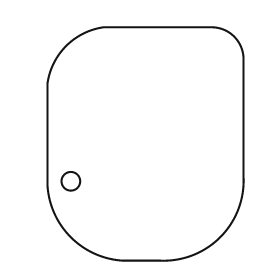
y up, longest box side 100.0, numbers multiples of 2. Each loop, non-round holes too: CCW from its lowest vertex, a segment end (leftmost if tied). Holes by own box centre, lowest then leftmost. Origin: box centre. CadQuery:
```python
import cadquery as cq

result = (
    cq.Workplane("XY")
    .moveTo(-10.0, -50.0)
    .lineTo(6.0, -50.0)
    .threePointArc((32.0, -40.0), (42.0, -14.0))
    .lineTo(42.0, 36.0)
    .threePointArc((38.0, 46.0), (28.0, 50.0))
    .lineTo(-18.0, 50.0)
    .threePointArc((-34.0, 42.0), (-42.0, 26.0))
    .lineTo(-42.0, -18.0)
    .threePointArc((-32.0, -40.0), (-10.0, -50.0))
    .close()
    .moveTo(-32.0, -16.0)
    .circle(4.0)
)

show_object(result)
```